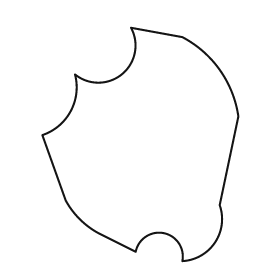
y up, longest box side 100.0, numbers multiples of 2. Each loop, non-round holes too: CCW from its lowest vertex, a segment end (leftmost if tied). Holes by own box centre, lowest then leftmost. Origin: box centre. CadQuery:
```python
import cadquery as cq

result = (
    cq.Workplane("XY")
    .moveTo(18.0, -50.0)
    .threePointArc((32.0, -42.0), (34.0, -26.0))
    .lineTo(42.0, 12.0)
    .threePointArc((34.0, 32.0), (18.0, 46.0))
    .lineTo(-4.0, 50.0)
    .threePointArc((-8.0, 30.0), (-28.0, 30.0))
    .threePointArc((-30.0, 14.0), (-42.0, 4.0))
    .lineTo(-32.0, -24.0)
    .threePointArc((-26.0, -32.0), (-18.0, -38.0))
    .lineTo(-2.0, -46.0)
    .threePointArc((10.0, -38.0), (18.0, -50.0))
    .close()
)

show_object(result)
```